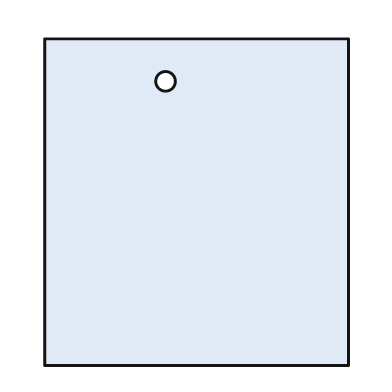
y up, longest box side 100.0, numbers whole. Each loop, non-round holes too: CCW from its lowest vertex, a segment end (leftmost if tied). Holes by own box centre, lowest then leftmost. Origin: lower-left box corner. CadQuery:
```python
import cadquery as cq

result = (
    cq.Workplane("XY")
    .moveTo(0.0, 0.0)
    .lineTo(93.0, 0.0)
    .lineTo(93.0, 100.0)
    .lineTo(0.0, 100.0)
    .close()
    .moveTo(37.0, 87.0)
    .circle(3.0)
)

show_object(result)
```